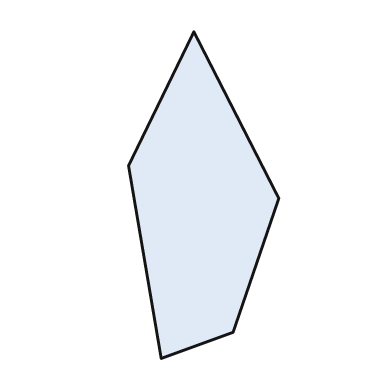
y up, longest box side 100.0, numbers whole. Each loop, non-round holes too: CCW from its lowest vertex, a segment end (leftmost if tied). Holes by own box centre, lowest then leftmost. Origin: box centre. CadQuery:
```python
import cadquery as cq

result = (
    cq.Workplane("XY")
    .moveTo(-13.0, -50.0)
    .lineTo(9.0, -42.0)
    .lineTo(23.0, -1.0)
    .lineTo(-3.0, 50.0)
    .lineTo(-23.0, 9.0)
    .close()
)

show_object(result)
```